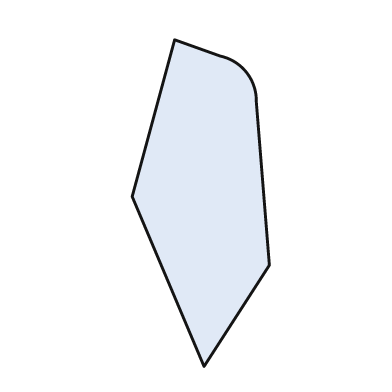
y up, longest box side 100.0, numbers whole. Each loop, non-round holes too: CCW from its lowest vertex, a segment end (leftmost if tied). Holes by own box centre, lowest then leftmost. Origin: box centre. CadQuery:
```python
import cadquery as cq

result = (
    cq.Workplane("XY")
    .moveTo(1.0, -50.0)
    .lineTo(21.0, -19.0)
    .lineTo(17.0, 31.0)
    .threePointArc((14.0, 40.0), (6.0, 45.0))
    .lineTo(-8.0, 50.0)
    .lineTo(-21.0, 2.0)
    .close()
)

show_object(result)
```